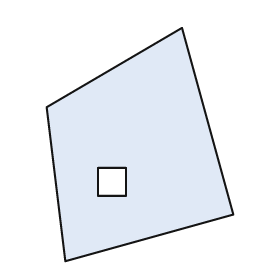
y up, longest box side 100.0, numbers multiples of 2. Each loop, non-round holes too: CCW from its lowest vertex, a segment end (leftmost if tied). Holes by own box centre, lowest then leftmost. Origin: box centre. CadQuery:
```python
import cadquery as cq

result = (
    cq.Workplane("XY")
    .moveTo(-32.0, -50.0)
    .lineTo(40.0, -30.0)
    .lineTo(18.0, 50.0)
    .lineTo(-40.0, 16.0)
    .close()
    .moveTo(-18.0, -22.0)
    .lineTo(-6.0, -22.0)
    .lineTo(-6.0, -10.0)
    .lineTo(-18.0, -10.0)
    .close()
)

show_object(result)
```